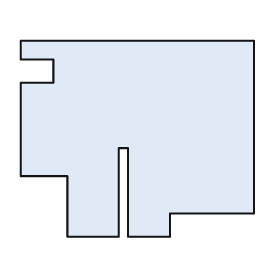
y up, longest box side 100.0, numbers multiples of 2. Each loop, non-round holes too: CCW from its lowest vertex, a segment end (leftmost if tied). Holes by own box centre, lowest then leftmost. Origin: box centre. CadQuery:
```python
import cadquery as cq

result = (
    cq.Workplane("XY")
    .moveTo(-30.0, -42.0)
    .lineTo(-8.0, -42.0)
    .lineTo(-8.0, -4.0)
    .lineTo(-4.0, -4.0)
    .lineTo(-4.0, -42.0)
    .lineTo(14.0, -42.0)
    .lineTo(14.0, -32.0)
    .lineTo(50.0, -32.0)
    .lineTo(50.0, 42.0)
    .lineTo(-50.0, 42.0)
    .lineTo(-50.0, 34.0)
    .lineTo(-36.0, 34.0)
    .lineTo(-36.0, 24.0)
    .lineTo(-50.0, 24.0)
    .lineTo(-50.0, -16.0)
    .lineTo(-30.0, -16.0)
    .close()
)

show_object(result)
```